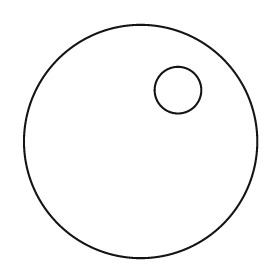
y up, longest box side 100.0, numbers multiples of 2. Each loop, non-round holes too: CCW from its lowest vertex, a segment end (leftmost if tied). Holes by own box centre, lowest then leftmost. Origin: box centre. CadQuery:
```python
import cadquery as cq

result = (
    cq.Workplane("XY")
    .moveTo(0.0, 0.0)
    .circle(50.0)
    .moveTo(16.0, 22.0)
    .circle(10.0)
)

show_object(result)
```